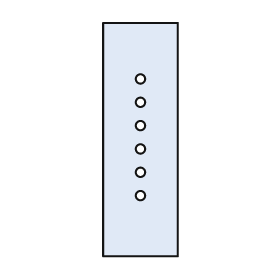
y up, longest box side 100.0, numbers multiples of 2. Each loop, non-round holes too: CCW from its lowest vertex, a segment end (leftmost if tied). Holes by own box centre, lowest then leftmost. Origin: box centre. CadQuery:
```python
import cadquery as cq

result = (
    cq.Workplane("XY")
    .moveTo(-16.0, -50.0)
    .lineTo(16.0, -50.0)
    .lineTo(16.0, 50.0)
    .lineTo(-16.0, 50.0)
    .close()
    .moveTo(0.0, -24.0)
    .circle(2.0)
    .moveTo(0.0, -14.0)
    .circle(2.0)
    .moveTo(0.0, -4.0)
    .circle(2.0)
    .moveTo(0.0, 6.0)
    .circle(2.0)
    .moveTo(0.0, 16.0)
    .circle(2.0)
    .moveTo(0.0, 26.0)
    .circle(2.0)
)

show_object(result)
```